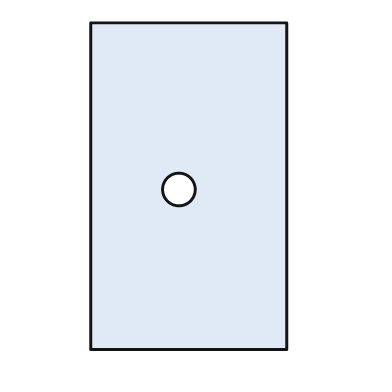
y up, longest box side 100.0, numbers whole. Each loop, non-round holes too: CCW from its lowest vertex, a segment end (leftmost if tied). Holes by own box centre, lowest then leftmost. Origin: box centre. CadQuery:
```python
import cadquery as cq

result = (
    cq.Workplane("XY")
    .moveTo(-30.0, -50.0)
    .lineTo(30.0, -50.0)
    .lineTo(30.0, 50.0)
    .lineTo(-30.0, 50.0)
    .close()
    .moveTo(-3.0, -1.0)
    .circle(5.0)
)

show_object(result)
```